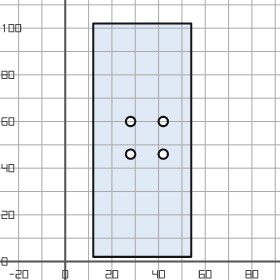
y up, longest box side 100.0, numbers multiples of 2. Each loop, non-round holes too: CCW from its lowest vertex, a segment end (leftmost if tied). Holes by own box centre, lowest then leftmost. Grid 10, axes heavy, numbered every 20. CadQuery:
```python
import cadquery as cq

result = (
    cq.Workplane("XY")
    .moveTo(12.0, 2.0)
    .lineTo(54.0, 2.0)
    .lineTo(54.0, 102.0)
    .lineTo(12.0, 102.0)
    .close()
    .moveTo(28.0, 46.0)
    .circle(2.0)
    .moveTo(42.0, 46.0)
    .circle(2.0)
    .moveTo(28.0, 60.0)
    .circle(2.0)
    .moveTo(42.0, 60.0)
    .circle(2.0)
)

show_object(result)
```